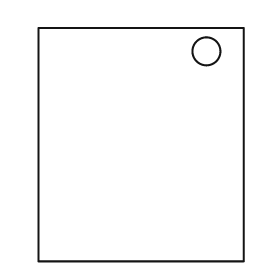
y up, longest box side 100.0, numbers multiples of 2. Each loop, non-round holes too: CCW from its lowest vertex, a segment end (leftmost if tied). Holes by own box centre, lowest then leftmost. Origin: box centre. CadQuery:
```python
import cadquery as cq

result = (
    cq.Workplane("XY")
    .moveTo(-44.0, -50.0)
    .lineTo(44.0, -50.0)
    .lineTo(44.0, 50.0)
    .lineTo(-44.0, 50.0)
    .close()
    .moveTo(28.0, 40.0)
    .circle(6.0)
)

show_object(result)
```